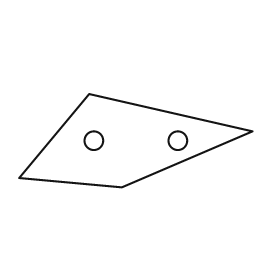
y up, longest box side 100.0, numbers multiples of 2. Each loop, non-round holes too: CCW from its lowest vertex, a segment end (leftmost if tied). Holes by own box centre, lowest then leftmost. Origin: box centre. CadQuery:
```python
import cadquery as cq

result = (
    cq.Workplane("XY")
    .moveTo(-6.0, -20.0)
    .lineTo(50.0, 4.0)
    .lineTo(-20.0, 20.0)
    .lineTo(-50.0, -16.0)
    .close()
    .moveTo(-18.0, 0.0)
    .circle(4.0)
    .moveTo(18.0, 0.0)
    .circle(4.0)
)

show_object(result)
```